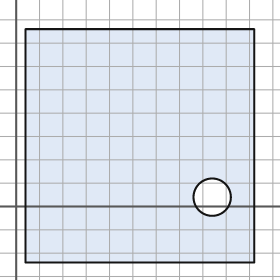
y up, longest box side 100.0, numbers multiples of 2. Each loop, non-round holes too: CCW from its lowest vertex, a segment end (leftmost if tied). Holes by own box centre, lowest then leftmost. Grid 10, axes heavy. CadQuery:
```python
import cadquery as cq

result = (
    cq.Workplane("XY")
    .moveTo(4.0, -24.0)
    .lineTo(102.0, -24.0)
    .lineTo(102.0, 76.0)
    .lineTo(4.0, 76.0)
    .close()
    .moveTo(84.0, 4.0)
    .circle(8.0)
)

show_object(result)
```